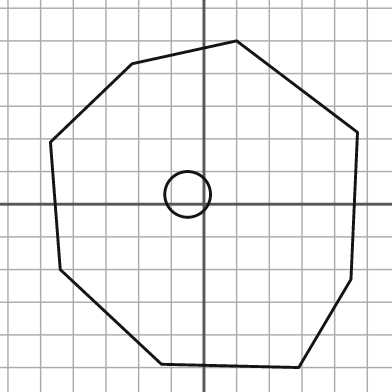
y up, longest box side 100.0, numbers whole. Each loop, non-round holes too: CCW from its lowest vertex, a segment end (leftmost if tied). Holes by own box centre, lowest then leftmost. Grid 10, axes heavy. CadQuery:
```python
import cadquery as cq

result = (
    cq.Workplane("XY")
    .moveTo(29.0, -50.0)
    .lineTo(45.0, -23.0)
    .lineTo(47.0, 22.0)
    .lineTo(10.0, 50.0)
    .lineTo(-22.0, 43.0)
    .lineTo(-47.0, 19.0)
    .lineTo(-44.0, -20.0)
    .lineTo(-13.0, -49.0)
    .close()
    .moveTo(-5.0, 3.0)
    .circle(7.0)
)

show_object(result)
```